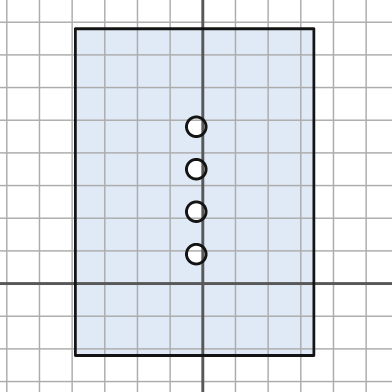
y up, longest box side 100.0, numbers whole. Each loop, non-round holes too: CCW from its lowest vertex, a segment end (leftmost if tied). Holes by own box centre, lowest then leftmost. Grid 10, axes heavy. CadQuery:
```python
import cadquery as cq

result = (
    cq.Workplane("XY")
    .moveTo(-39.0, -22.0)
    .lineTo(34.0, -22.0)
    .lineTo(34.0, 78.0)
    .lineTo(-39.0, 78.0)
    .close()
    .moveTo(-2.0, 9.0)
    .circle(3.0)
    .moveTo(-2.0, 22.0)
    .circle(3.0)
    .moveTo(-2.0, 35.0)
    .circle(3.0)
    .moveTo(-2.0, 48.0)
    .circle(3.0)
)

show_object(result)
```